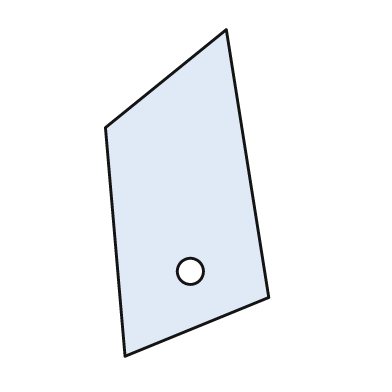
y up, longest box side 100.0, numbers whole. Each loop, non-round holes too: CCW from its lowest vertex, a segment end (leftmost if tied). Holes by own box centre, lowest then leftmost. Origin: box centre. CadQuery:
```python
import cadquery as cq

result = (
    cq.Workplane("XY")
    .moveTo(-19.0, -50.0)
    .lineTo(25.0, -32.0)
    .lineTo(12.0, 50.0)
    .lineTo(-25.0, 20.0)
    .close()
    .moveTo(1.0, -24.0)
    .circle(4.0)
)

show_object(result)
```